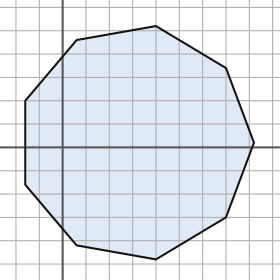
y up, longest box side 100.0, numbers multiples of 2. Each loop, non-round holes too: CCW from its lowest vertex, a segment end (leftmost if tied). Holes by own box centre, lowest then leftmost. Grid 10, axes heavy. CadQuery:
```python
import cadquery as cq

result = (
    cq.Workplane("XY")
    .moveTo(40.0, -48.0)
    .lineTo(70.0, -30.0)
    .lineTo(82.0, 2.0)
    .lineTo(70.0, 34.0)
    .lineTo(40.0, 52.0)
    .lineTo(6.0, 46.0)
    .lineTo(-16.0, 20.0)
    .lineTo(-16.0, -16.0)
    .lineTo(6.0, -42.0)
    .close()
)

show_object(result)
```